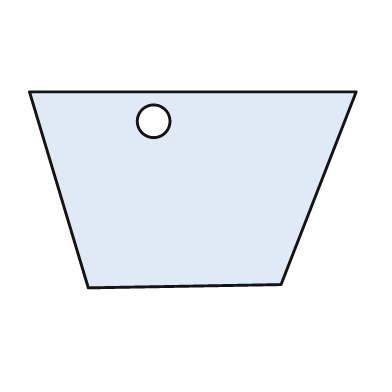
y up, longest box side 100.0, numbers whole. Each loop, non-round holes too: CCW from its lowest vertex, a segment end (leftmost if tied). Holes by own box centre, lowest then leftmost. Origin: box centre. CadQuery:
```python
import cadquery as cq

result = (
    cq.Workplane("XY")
    .moveTo(-32.0, -30.0)
    .lineTo(27.0, -29.0)
    .lineTo(50.0, 30.0)
    .lineTo(-50.0, 30.0)
    .close()
    .moveTo(-12.0, 21.0)
    .circle(5.0)
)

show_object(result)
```